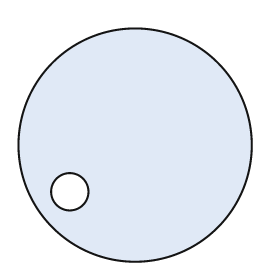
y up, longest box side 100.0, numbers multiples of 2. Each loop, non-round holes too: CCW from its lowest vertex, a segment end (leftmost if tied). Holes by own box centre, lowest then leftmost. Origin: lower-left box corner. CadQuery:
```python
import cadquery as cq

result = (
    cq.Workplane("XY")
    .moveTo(50.0, 50.0)
    .circle(50.0)
    .moveTo(22.0, 30.0)
    .circle(8.0)
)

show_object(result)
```